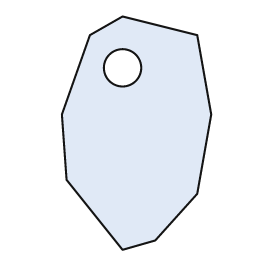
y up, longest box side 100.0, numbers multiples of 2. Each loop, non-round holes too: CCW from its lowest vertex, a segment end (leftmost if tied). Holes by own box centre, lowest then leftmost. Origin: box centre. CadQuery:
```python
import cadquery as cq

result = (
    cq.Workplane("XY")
    .moveTo(-6.0, -50.0)
    .lineTo(8.0, -46.0)
    .lineTo(26.0, -26.0)
    .lineTo(32.0, 8.0)
    .lineTo(26.0, 42.0)
    .lineTo(-6.0, 50.0)
    .lineTo(-20.0, 42.0)
    .lineTo(-32.0, 8.0)
    .lineTo(-30.0, -20.0)
    .close()
    .moveTo(-6.0, 28.0)
    .circle(8.0)
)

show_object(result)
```